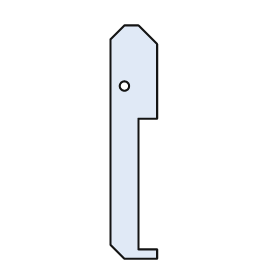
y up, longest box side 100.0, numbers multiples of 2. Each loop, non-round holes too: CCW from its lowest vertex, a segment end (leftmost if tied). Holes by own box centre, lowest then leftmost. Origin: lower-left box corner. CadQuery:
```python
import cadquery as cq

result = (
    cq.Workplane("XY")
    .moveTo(6.0, 0.0)
    .lineTo(20.0, 0.0)
    .lineTo(20.0, 4.0)
    .lineTo(12.0, 4.0)
    .lineTo(12.0, 60.0)
    .lineTo(20.0, 60.0)
    .lineTo(20.0, 92.0)
    .lineTo(12.0, 100.0)
    .lineTo(6.0, 100.0)
    .lineTo(0.0, 94.0)
    .lineTo(0.0, 6.0)
    .close()
    .moveTo(6.0, 74.0)
    .circle(2.0)
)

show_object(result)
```